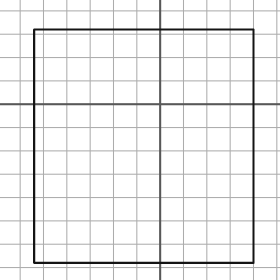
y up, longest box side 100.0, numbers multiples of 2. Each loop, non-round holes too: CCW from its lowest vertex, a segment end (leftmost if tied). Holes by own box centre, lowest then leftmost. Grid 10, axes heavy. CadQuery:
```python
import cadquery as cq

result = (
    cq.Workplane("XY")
    .moveTo(-54.0, -68.0)
    .lineTo(40.0, -68.0)
    .lineTo(40.0, 32.0)
    .lineTo(-54.0, 32.0)
    .close()
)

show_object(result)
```